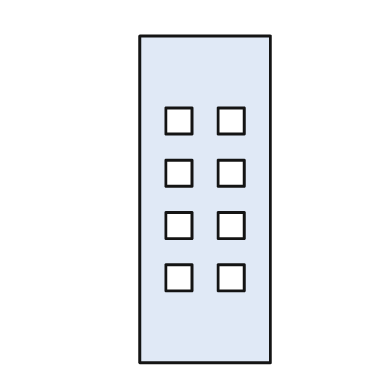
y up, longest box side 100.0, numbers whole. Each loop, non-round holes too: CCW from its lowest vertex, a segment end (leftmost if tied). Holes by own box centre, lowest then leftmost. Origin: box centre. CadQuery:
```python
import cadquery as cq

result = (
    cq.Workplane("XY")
    .moveTo(-20.0, -50.0)
    .lineTo(20.0, -50.0)
    .lineTo(20.0, 50.0)
    .lineTo(-20.0, 50.0)
    .close()
    .moveTo(-12.0, -28.0)
    .lineTo(-4.0, -28.0)
    .lineTo(-4.0, -20.0)
    .lineTo(-12.0, -20.0)
    .close()
    .moveTo(4.0, -28.0)
    .lineTo(12.0, -28.0)
    .lineTo(12.0, -20.0)
    .lineTo(4.0, -20.0)
    .close()
    .moveTo(-12.0, -12.0)
    .lineTo(-4.0, -12.0)
    .lineTo(-4.0, -4.0)
    .lineTo(-12.0, -4.0)
    .close()
    .moveTo(4.0, -12.0)
    .lineTo(12.0, -12.0)
    .lineTo(12.0, -4.0)
    .lineTo(4.0, -4.0)
    .close()
    .moveTo(-12.0, 4.0)
    .lineTo(-4.0, 4.0)
    .lineTo(-4.0, 12.0)
    .lineTo(-12.0, 12.0)
    .close()
    .moveTo(4.0, 4.0)
    .lineTo(12.0, 4.0)
    .lineTo(12.0, 12.0)
    .lineTo(4.0, 12.0)
    .close()
    .moveTo(-12.0, 20.0)
    .lineTo(-4.0, 20.0)
    .lineTo(-4.0, 28.0)
    .lineTo(-12.0, 28.0)
    .close()
    .moveTo(4.0, 20.0)
    .lineTo(12.0, 20.0)
    .lineTo(12.0, 28.0)
    .lineTo(4.0, 28.0)
    .close()
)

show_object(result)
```